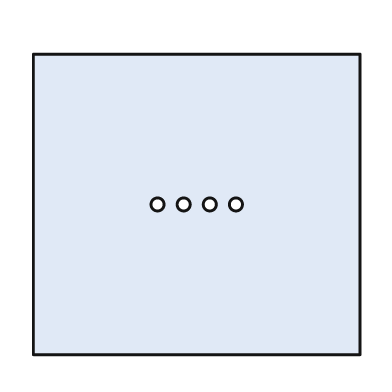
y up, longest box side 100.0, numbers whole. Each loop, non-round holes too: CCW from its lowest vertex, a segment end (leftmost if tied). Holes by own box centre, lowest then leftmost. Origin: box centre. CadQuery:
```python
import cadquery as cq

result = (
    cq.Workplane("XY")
    .moveTo(-50.0, -46.0)
    .lineTo(50.0, -46.0)
    .lineTo(50.0, 46.0)
    .lineTo(-50.0, 46.0)
    .close()
    .moveTo(-12.0, 0.0)
    .circle(2.0)
    .moveTo(-4.0, 0.0)
    .circle(2.0)
    .moveTo(4.0, 0.0)
    .circle(2.0)
    .moveTo(12.0, 0.0)
    .circle(2.0)
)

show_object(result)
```